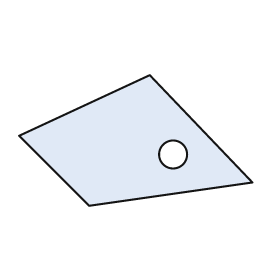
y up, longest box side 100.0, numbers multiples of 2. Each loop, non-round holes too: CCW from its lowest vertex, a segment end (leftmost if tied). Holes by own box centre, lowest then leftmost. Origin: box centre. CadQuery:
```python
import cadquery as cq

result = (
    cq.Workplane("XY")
    .moveTo(-20.0, -28.0)
    .lineTo(50.0, -18.0)
    .lineTo(6.0, 28.0)
    .lineTo(-50.0, 2.0)
    .close()
    .moveTo(16.0, -6.0)
    .circle(6.0)
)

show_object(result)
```